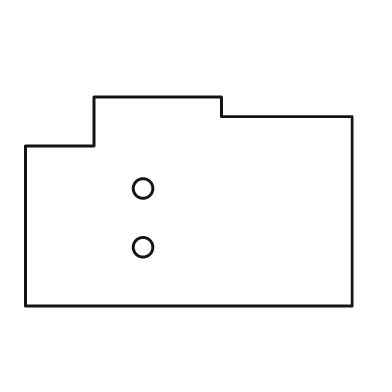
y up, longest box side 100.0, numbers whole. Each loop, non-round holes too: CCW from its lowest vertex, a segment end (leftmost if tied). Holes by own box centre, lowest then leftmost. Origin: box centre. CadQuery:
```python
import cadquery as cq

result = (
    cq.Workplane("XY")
    .moveTo(-50.0, -32.0)
    .lineTo(50.0, -32.0)
    .lineTo(50.0, 26.0)
    .lineTo(10.0, 26.0)
    .lineTo(10.0, 32.0)
    .lineTo(-29.0, 32.0)
    .lineTo(-29.0, 17.0)
    .lineTo(-50.0, 17.0)
    .close()
    .moveTo(-14.0, -14.0)
    .circle(3.0)
    .moveTo(-14.0, 4.0)
    .circle(3.0)
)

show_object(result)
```